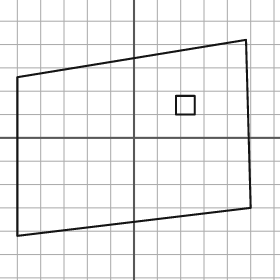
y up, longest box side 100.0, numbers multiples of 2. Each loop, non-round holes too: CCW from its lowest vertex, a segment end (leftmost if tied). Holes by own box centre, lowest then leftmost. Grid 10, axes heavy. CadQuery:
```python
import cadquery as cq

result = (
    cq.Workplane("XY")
    .moveTo(-50.0, -42.0)
    .lineTo(50.0, -30.0)
    .lineTo(48.0, 42.0)
    .lineTo(-50.0, 26.0)
    .close()
    .moveTo(18.0, 10.0)
    .lineTo(26.0, 10.0)
    .lineTo(26.0, 18.0)
    .lineTo(18.0, 18.0)
    .close()
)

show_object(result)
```